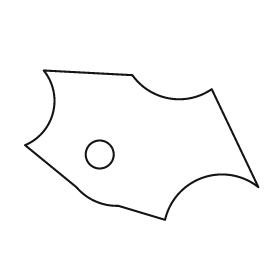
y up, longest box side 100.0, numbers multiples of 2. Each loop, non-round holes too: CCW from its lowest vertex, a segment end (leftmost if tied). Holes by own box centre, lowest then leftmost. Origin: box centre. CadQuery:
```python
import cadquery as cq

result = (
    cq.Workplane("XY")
    .moveTo(10.0, -32.0)
    .threePointArc((26.0, -14.0), (50.0, -18.0))
    .lineTo(30.0, 24.0)
    .threePointArc((12.0, 20.0), (-4.0, 30.0))
    .lineTo(-42.0, 32.0)
    .threePointArc((-38.0, 14.0), (-50.0, 0.0))
    .lineTo(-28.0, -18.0)
    .threePointArc((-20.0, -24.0), (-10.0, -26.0))
    .close()
    .moveTo(-18.0, -4.0)
    .circle(6.0)
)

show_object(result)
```